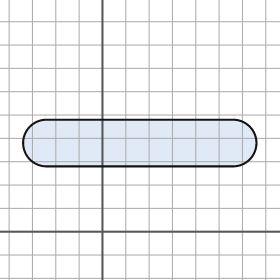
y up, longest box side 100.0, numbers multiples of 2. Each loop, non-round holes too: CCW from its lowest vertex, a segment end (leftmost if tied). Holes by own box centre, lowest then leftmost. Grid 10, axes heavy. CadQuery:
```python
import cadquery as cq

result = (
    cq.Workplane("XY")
    .moveTo(-24.0, 28.0)
    .lineTo(56.0, 28.0)
    .threePointArc((66.0, 38.0), (56.0, 48.0))
    .lineTo(-24.0, 48.0)
    .threePointArc((-34.0, 38.0), (-24.0, 28.0))
    .close()
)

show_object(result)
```